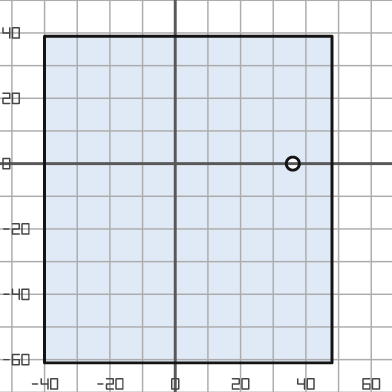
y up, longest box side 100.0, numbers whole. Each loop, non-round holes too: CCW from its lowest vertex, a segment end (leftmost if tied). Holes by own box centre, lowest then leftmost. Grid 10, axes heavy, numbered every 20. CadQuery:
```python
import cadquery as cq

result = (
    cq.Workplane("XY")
    .moveTo(-40.0, -61.0)
    .lineTo(48.0, -61.0)
    .lineTo(48.0, 39.0)
    .lineTo(-40.0, 39.0)
    .close()
    .moveTo(36.0, 0.0)
    .circle(2.0)
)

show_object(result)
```